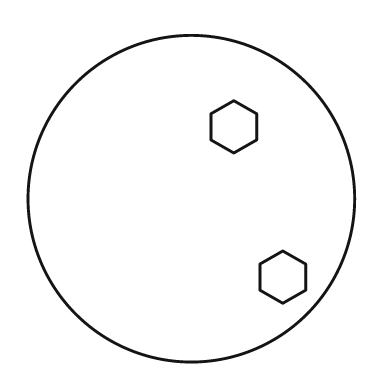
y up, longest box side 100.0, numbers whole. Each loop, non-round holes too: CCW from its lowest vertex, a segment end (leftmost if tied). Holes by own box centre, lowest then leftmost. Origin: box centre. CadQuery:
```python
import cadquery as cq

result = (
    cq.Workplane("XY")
    .moveTo(0.0, 0.0)
    .circle(50.0)
    .moveTo(28.0, -32.0)
    .lineTo(35.0, -28.0)
    .lineTo(35.0, -20.0)
    .lineTo(28.0, -16.0)
    .lineTo(21.0, -20.0)
    .lineTo(21.0, -28.0)
    .close()
    .moveTo(13.0, 14.0)
    .lineTo(20.0, 18.0)
    .lineTo(20.0, 26.0)
    .lineTo(13.0, 30.0)
    .lineTo(6.0, 26.0)
    .lineTo(6.0, 18.0)
    .close()
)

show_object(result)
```